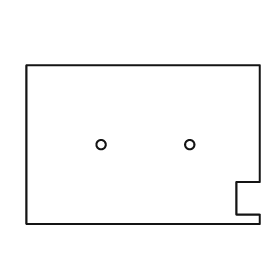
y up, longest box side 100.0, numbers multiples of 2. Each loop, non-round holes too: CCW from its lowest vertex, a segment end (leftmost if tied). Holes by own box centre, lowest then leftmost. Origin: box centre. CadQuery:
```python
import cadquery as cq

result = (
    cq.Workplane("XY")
    .moveTo(-50.0, -34.0)
    .lineTo(50.0, -34.0)
    .lineTo(50.0, -30.0)
    .lineTo(40.0, -30.0)
    .lineTo(40.0, -16.0)
    .lineTo(50.0, -16.0)
    .lineTo(50.0, 34.0)
    .lineTo(-50.0, 34.0)
    .close()
    .moveTo(-18.0, 0.0)
    .circle(2.0)
    .moveTo(20.0, 0.0)
    .circle(2.0)
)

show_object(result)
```